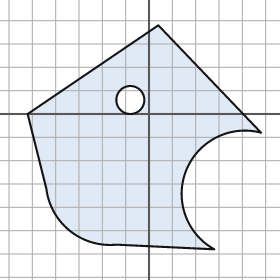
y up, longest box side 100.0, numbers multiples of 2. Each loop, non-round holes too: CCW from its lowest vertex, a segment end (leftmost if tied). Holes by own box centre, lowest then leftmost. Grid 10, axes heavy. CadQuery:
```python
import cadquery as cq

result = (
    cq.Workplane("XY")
    .moveTo(28.0, -58.0)
    .threePointArc((16.0, -24.0), (48.0, -8.0))
    .lineTo(4.0, 38.0)
    .lineTo(-52.0, 0.0)
    .lineTo(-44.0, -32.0)
    .threePointArc((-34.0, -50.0), (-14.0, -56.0))
    .close()
    .moveTo(-8.0, 6.0)
    .circle(6.0)
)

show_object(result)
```